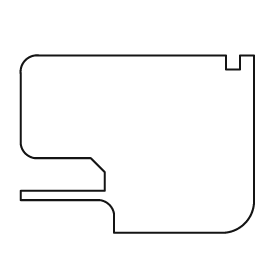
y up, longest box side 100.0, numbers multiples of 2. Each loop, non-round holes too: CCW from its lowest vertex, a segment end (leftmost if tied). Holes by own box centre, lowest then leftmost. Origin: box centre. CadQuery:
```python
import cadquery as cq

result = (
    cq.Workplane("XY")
    .moveTo(-10.0, -38.0)
    .lineTo(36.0, -38.0)
    .threePointArc((46.0, -34.0), (50.0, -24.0))
    .lineTo(50.0, 38.0)
    .lineTo(44.0, 38.0)
    .lineTo(44.0, 32.0)
    .lineTo(38.0, 32.0)
    .lineTo(38.0, 38.0)
    .lineTo(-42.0, 38.0)
    .threePointArc((-48.0, 36.0), (-50.0, 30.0))
    .lineTo(-50.0, 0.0)
    .threePointArc((-48.0, -4.0), (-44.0, -6.0))
    .lineTo(-20.0, -6.0)
    .lineTo(-14.0, -12.0)
    .lineTo(-14.0, -20.0)
    .lineTo(-50.0, -20.0)
    .lineTo(-50.0, -24.0)
    .lineTo(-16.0, -24.0)
    .threePointArc((-12.0, -26.0), (-10.0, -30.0))
    .close()
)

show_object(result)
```